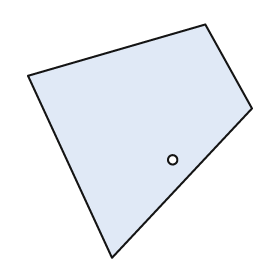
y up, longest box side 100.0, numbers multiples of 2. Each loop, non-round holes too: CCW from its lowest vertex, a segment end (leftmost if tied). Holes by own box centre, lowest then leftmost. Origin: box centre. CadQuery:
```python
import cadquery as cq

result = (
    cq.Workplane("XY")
    .moveTo(-12.0, -50.0)
    .lineTo(48.0, 14.0)
    .lineTo(28.0, 50.0)
    .lineTo(-48.0, 28.0)
    .close()
    .moveTo(14.0, -8.0)
    .circle(2.0)
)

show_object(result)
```